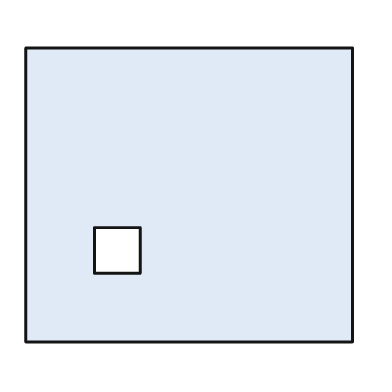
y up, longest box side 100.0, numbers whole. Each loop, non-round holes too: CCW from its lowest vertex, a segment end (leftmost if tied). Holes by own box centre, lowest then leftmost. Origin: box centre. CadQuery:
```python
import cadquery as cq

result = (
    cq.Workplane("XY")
    .moveTo(-50.0, -45.0)
    .lineTo(50.0, -45.0)
    .lineTo(50.0, 45.0)
    .lineTo(-50.0, 45.0)
    .close()
    .moveTo(-29.0, -24.0)
    .lineTo(-15.0, -24.0)
    .lineTo(-15.0, -10.0)
    .lineTo(-29.0, -10.0)
    .close()
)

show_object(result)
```